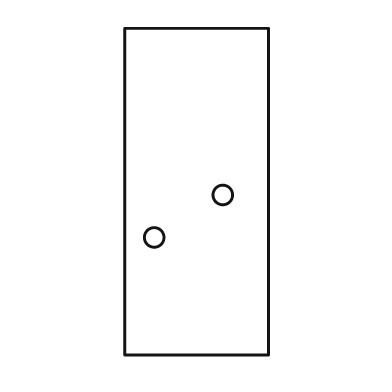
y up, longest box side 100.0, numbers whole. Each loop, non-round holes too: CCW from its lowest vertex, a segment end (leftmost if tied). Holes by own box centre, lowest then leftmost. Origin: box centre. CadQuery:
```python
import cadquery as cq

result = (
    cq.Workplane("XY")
    .moveTo(-22.0, -50.0)
    .lineTo(22.0, -50.0)
    .lineTo(22.0, 50.0)
    .lineTo(-22.0, 50.0)
    .close()
    .moveTo(-13.0, -14.0)
    .circle(3.0)
    .moveTo(8.0, -1.0)
    .circle(3.0)
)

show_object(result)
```